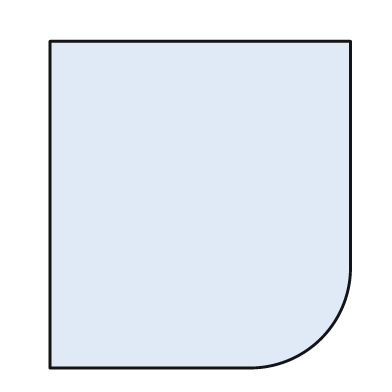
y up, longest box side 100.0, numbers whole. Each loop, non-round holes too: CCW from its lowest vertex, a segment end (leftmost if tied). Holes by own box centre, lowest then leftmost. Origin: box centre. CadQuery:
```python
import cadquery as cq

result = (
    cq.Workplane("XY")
    .moveTo(-46.0, -50.0)
    .lineTo(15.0, -50.0)
    .threePointArc((37.0, -41.0), (46.0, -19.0))
    .lineTo(46.0, 50.0)
    .lineTo(-46.0, 50.0)
    .close()
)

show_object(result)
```